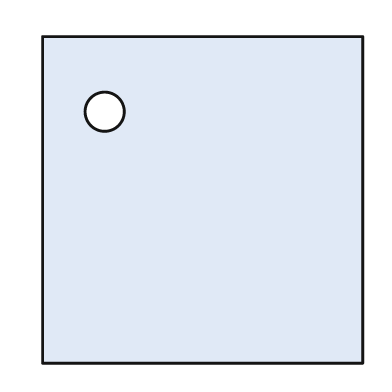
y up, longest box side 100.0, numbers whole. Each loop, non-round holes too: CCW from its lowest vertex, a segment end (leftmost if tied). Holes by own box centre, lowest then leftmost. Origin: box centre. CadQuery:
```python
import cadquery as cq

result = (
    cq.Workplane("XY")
    .moveTo(-49.0, -50.0)
    .lineTo(49.0, -50.0)
    .lineTo(49.0, 50.0)
    .lineTo(-49.0, 50.0)
    .close()
    .moveTo(-30.0, 27.0)
    .circle(6.0)
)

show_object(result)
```